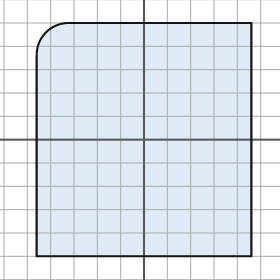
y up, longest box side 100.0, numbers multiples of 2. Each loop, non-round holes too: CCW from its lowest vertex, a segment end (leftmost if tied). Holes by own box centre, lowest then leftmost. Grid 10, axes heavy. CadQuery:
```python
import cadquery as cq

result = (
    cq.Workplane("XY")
    .moveTo(-46.0, -50.0)
    .lineTo(46.0, -50.0)
    .lineTo(46.0, 50.0)
    .lineTo(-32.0, 50.0)
    .threePointArc((-42.0, 46.0), (-46.0, 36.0))
    .close()
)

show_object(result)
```